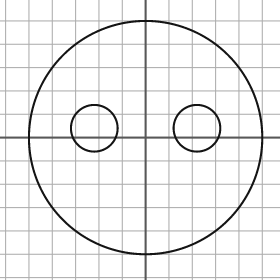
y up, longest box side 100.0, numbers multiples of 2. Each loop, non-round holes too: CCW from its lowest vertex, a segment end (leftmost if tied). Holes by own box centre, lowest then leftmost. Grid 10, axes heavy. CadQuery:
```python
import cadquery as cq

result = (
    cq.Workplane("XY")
    .moveTo(0.0, 0.0)
    .circle(50.0)
    .moveTo(-22.0, 4.0)
    .circle(10.0)
    .moveTo(22.0, 4.0)
    .circle(10.0)
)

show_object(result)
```